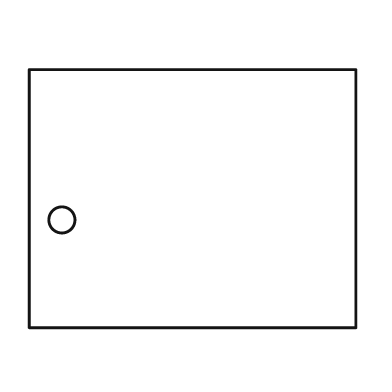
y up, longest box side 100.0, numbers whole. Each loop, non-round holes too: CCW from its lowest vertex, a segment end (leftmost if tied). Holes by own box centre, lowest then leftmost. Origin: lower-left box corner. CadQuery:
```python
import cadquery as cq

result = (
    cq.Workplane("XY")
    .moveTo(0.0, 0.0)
    .lineTo(100.0, 0.0)
    .lineTo(100.0, 79.0)
    .lineTo(0.0, 79.0)
    .close()
    .moveTo(10.0, 33.0)
    .circle(4.0)
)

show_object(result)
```